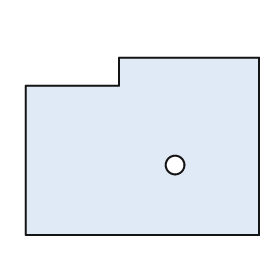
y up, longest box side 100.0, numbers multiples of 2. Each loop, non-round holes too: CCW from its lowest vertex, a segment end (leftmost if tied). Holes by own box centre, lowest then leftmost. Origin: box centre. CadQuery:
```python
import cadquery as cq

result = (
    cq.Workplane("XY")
    .moveTo(-50.0, -38.0)
    .lineTo(50.0, -38.0)
    .lineTo(50.0, 38.0)
    .lineTo(-10.0, 38.0)
    .lineTo(-10.0, 26.0)
    .lineTo(-50.0, 26.0)
    .close()
    .moveTo(14.0, -8.0)
    .circle(4.0)
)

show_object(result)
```